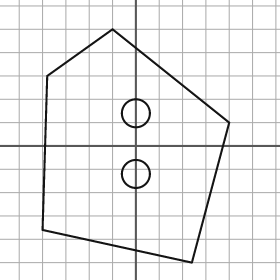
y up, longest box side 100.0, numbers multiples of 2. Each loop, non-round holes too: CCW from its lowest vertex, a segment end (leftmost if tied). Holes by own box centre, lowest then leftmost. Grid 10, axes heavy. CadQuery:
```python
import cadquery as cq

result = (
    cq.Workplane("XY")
    .moveTo(24.0, -50.0)
    .lineTo(40.0, 10.0)
    .lineTo(-10.0, 50.0)
    .lineTo(-38.0, 30.0)
    .lineTo(-40.0, -36.0)
    .close()
    .moveTo(0.0, -12.0)
    .circle(6.0)
    .moveTo(0.0, 14.0)
    .circle(6.0)
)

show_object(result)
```